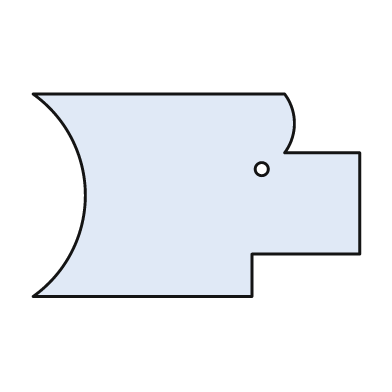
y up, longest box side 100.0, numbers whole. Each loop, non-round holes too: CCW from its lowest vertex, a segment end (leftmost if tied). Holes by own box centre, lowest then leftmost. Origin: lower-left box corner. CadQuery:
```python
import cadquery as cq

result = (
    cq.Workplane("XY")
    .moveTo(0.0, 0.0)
    .lineTo(67.0, 0.0)
    .lineTo(67.0, 13.0)
    .lineTo(100.0, 13.0)
    .lineTo(100.0, 44.0)
    .lineTo(77.0, 44.0)
    .threePointArc((80.0, 53.0), (77.0, 62.0))
    .lineTo(0.0, 62.0)
    .threePointArc((16.0, 31.0), (0.0, 0.0))
    .close()
    .moveTo(70.0, 39.0)
    .circle(2.0)
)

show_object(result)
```